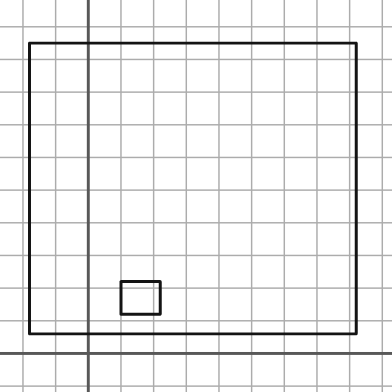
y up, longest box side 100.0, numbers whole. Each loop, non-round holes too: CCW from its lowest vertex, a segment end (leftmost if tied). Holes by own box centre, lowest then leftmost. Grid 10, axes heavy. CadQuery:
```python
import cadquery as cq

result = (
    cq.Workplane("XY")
    .moveTo(-18.0, 6.0)
    .lineTo(82.0, 6.0)
    .lineTo(82.0, 95.0)
    .lineTo(-18.0, 95.0)
    .close()
    .moveTo(10.0, 12.0)
    .lineTo(22.0, 12.0)
    .lineTo(22.0, 22.0)
    .lineTo(10.0, 22.0)
    .close()
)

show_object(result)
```